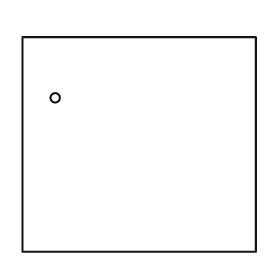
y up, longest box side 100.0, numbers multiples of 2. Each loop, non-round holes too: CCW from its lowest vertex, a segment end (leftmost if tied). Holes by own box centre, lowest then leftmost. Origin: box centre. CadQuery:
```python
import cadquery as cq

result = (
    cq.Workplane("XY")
    .moveTo(-50.0, -46.0)
    .lineTo(50.0, -46.0)
    .lineTo(50.0, 46.0)
    .lineTo(-50.0, 46.0)
    .close()
    .moveTo(-36.0, 20.0)
    .circle(2.0)
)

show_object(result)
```